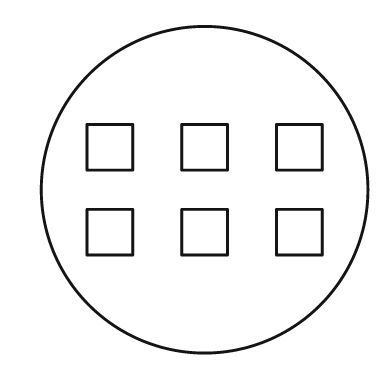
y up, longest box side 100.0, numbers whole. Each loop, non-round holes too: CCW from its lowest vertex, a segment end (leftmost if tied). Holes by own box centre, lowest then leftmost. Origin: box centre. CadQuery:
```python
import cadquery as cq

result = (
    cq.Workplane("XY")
    .moveTo(0.0, 0.0)
    .circle(50.0)
    .moveTo(-36.0, -20.0)
    .lineTo(-22.0, -20.0)
    .lineTo(-22.0, -6.0)
    .lineTo(-36.0, -6.0)
    .close()
    .moveTo(-7.0, -20.0)
    .lineTo(7.0, -20.0)
    .lineTo(7.0, -6.0)
    .lineTo(-7.0, -6.0)
    .close()
    .moveTo(22.0, -20.0)
    .lineTo(36.0, -20.0)
    .lineTo(36.0, -6.0)
    .lineTo(22.0, -6.0)
    .close()
    .moveTo(-36.0, 6.0)
    .lineTo(-22.0, 6.0)
    .lineTo(-22.0, 20.0)
    .lineTo(-36.0, 20.0)
    .close()
    .moveTo(-7.0, 6.0)
    .lineTo(7.0, 6.0)
    .lineTo(7.0, 20.0)
    .lineTo(-7.0, 20.0)
    .close()
    .moveTo(22.0, 6.0)
    .lineTo(36.0, 6.0)
    .lineTo(36.0, 20.0)
    .lineTo(22.0, 20.0)
    .close()
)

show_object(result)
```